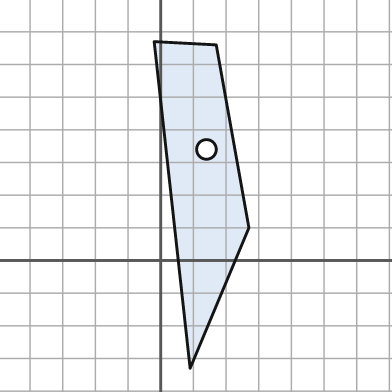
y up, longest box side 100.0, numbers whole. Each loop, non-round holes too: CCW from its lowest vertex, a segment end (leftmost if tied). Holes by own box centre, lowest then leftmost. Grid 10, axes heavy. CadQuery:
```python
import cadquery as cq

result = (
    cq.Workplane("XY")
    .moveTo(9.0, -33.0)
    .lineTo(27.0, 10.0)
    .lineTo(17.0, 66.0)
    .lineTo(-2.0, 67.0)
    .close()
    .moveTo(14.0, 34.0)
    .circle(3.0)
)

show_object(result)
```